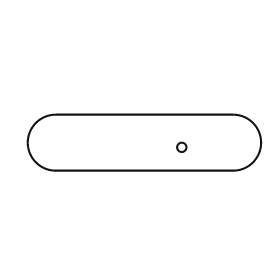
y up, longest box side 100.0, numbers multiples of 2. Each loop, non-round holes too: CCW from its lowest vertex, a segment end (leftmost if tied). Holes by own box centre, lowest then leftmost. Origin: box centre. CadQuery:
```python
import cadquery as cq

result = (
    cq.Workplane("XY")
    .moveTo(-38.0, -12.0)
    .lineTo(38.0, -12.0)
    .threePointArc((50.0, 0.0), (38.0, 12.0))
    .lineTo(-38.0, 12.0)
    .threePointArc((-50.0, 0.0), (-38.0, -12.0))
    .close()
    .moveTo(16.0, -2.0)
    .circle(2.0)
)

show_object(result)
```